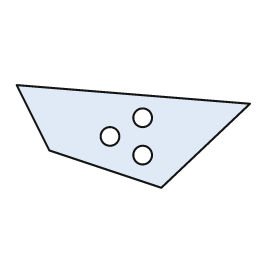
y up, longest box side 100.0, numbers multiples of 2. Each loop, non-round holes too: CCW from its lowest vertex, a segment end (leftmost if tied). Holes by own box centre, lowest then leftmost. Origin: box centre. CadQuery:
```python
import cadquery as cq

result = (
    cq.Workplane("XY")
    .moveTo(12.0, -22.0)
    .lineTo(50.0, 14.0)
    .lineTo(-50.0, 22.0)
    .lineTo(-36.0, -6.0)
    .close()
    .moveTo(4.0, -8.0)
    .circle(4.0)
    .moveTo(-10.0, 0.0)
    .circle(4.0)
    .moveTo(4.0, 8.0)
    .circle(4.0)
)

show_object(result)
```